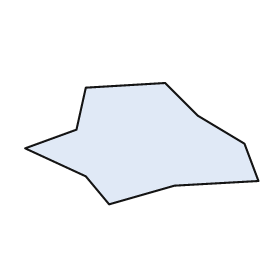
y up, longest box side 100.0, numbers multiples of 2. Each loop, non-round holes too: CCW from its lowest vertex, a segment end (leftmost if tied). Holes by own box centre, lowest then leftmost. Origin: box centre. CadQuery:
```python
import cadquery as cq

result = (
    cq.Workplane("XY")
    .moveTo(-14.0, -26.0)
    .lineTo(14.0, -18.0)
    .lineTo(50.0, -16.0)
    .lineTo(44.0, 0.0)
    .lineTo(24.0, 12.0)
    .lineTo(10.0, 26.0)
    .lineTo(-24.0, 24.0)
    .lineTo(-28.0, 6.0)
    .lineTo(-50.0, -2.0)
    .lineTo(-24.0, -14.0)
    .close()
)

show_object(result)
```